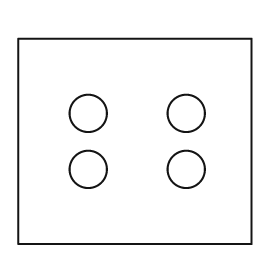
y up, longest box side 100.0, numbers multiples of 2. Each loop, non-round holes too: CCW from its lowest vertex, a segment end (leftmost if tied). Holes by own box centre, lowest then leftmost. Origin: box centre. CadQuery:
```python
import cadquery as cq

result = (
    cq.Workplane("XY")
    .moveTo(-50.0, -44.0)
    .lineTo(50.0, -44.0)
    .lineTo(50.0, 44.0)
    .lineTo(-50.0, 44.0)
    .close()
    .moveTo(-20.0, -12.0)
    .circle(8.0)
    .moveTo(22.0, -12.0)
    .circle(8.0)
    .moveTo(-20.0, 12.0)
    .circle(8.0)
    .moveTo(22.0, 12.0)
    .circle(8.0)
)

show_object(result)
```